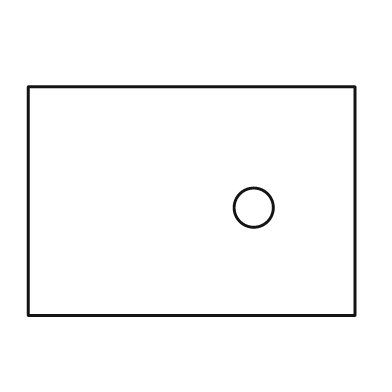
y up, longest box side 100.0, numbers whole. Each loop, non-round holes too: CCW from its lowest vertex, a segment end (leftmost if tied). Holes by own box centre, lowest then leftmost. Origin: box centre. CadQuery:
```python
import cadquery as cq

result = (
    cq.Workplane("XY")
    .moveTo(-50.0, -35.0)
    .lineTo(50.0, -35.0)
    .lineTo(50.0, 35.0)
    .lineTo(-50.0, 35.0)
    .close()
    .moveTo(19.0, -2.0)
    .circle(6.0)
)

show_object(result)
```